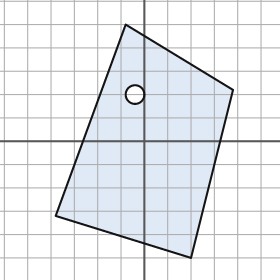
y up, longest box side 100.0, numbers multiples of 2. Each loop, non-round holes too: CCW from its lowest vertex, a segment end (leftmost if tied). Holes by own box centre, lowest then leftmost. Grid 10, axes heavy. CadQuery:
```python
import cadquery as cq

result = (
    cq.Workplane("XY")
    .moveTo(20.0, -50.0)
    .lineTo(38.0, 22.0)
    .lineTo(-8.0, 50.0)
    .lineTo(-38.0, -32.0)
    .close()
    .moveTo(-4.0, 20.0)
    .circle(4.0)
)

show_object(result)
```